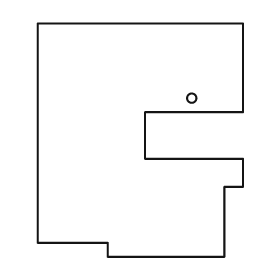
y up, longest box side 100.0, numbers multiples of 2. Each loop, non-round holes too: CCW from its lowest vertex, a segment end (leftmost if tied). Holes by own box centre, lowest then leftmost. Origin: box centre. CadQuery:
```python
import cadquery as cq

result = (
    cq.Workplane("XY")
    .moveTo(-14.0, -50.0)
    .lineTo(36.0, -50.0)
    .lineTo(36.0, -20.0)
    .lineTo(44.0, -20.0)
    .lineTo(44.0, -8.0)
    .lineTo(2.0, -8.0)
    .lineTo(2.0, 12.0)
    .lineTo(44.0, 12.0)
    .lineTo(44.0, 50.0)
    .lineTo(-44.0, 50.0)
    .lineTo(-44.0, -44.0)
    .lineTo(-14.0, -44.0)
    .close()
    .moveTo(22.0, 18.0)
    .circle(2.0)
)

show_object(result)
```